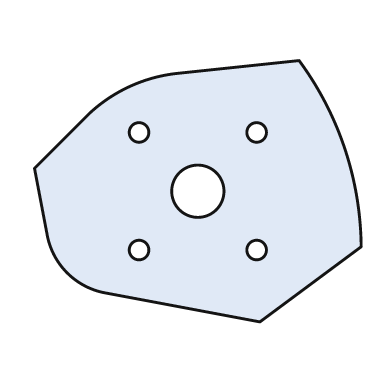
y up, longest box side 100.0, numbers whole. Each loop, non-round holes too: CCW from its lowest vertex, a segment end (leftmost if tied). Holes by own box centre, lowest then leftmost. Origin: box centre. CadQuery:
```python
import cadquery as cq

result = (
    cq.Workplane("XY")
    .moveTo(19.0, -40.0)
    .lineTo(50.0, -17.0)
    .threePointArc((45.0, 13.0), (31.0, 40.0))
    .lineTo(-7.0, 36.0)
    .threePointArc((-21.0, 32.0), (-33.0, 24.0))
    .lineTo(-50.0, 7.0)
    .lineTo(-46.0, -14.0)
    .threePointArc((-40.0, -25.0), (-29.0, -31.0))
    .close()
    .moveTo(-18.0, -18.0)
    .circle(3.0)
    .moveTo(18.0, -18.0)
    .circle(3.0)
    .moveTo(0.0, 0.0)
    .circle(8.0)
    .moveTo(-18.0, 18.0)
    .circle(3.0)
    .moveTo(18.0, 18.0)
    .circle(3.0)
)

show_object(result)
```